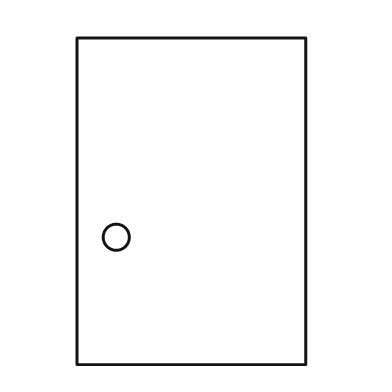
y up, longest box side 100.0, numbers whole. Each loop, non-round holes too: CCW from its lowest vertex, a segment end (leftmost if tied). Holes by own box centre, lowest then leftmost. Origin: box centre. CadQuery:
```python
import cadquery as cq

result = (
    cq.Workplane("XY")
    .moveTo(-35.0, -50.0)
    .lineTo(35.0, -50.0)
    .lineTo(35.0, 50.0)
    .lineTo(-35.0, 50.0)
    .close()
    .moveTo(-23.0, -11.0)
    .circle(4.0)
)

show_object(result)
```